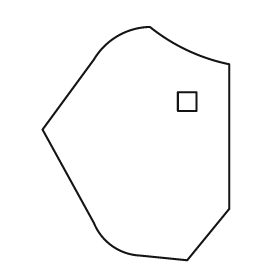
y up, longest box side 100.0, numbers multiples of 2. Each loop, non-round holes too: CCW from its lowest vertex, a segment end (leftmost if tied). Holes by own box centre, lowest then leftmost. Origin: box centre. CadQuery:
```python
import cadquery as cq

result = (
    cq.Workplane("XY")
    .moveTo(22.0, -50.0)
    .lineTo(40.0, -28.0)
    .lineTo(40.0, 34.0)
    .threePointArc((22.0, 40.0), (6.0, 50.0))
    .threePointArc((-8.0, 46.0), (-18.0, 36.0))
    .lineTo(-40.0, 6.0)
    .lineTo(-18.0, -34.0)
    .threePointArc((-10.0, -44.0), (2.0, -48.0))
    .close()
    .moveTo(18.0, 14.0)
    .lineTo(26.0, 14.0)
    .lineTo(26.0, 22.0)
    .lineTo(18.0, 22.0)
    .close()
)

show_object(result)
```